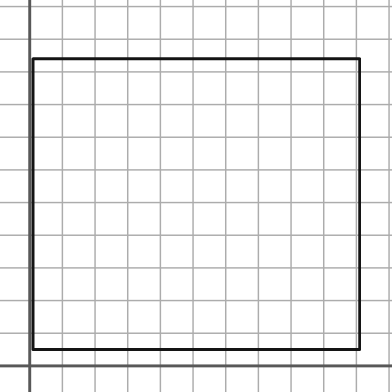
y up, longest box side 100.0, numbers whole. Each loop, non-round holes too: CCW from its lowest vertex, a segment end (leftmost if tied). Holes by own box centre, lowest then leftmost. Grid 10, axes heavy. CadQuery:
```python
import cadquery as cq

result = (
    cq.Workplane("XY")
    .moveTo(1.0, 5.0)
    .lineTo(101.0, 5.0)
    .lineTo(101.0, 94.0)
    .lineTo(1.0, 94.0)
    .close()
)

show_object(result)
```